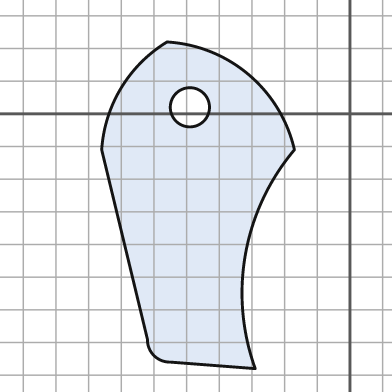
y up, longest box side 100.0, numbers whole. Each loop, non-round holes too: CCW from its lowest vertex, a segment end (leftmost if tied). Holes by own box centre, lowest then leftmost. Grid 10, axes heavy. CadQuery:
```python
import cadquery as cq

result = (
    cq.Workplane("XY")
    .moveTo(-29.0, -78.0)
    .threePointArc((-32.0, -43.0), (-17.0, -11.0))
    .threePointArc((-31.0, 12.0), (-56.0, 22.0))
    .threePointArc((-70.0, 8.0), (-76.0, -11.0))
    .lineTo(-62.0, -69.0)
    .threePointArc((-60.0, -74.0), (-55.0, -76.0))
    .close()
    .moveTo(-49.0, 2.0)
    .circle(6.0)
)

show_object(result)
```